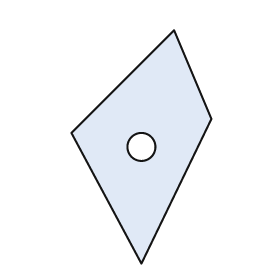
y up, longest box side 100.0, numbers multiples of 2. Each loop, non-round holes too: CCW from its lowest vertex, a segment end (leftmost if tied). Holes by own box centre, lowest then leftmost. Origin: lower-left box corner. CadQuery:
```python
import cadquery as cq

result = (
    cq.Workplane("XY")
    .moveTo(30.0, 0.0)
    .lineTo(60.0, 62.0)
    .lineTo(44.0, 100.0)
    .lineTo(0.0, 56.0)
    .close()
    .moveTo(30.0, 50.0)
    .circle(6.0)
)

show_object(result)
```